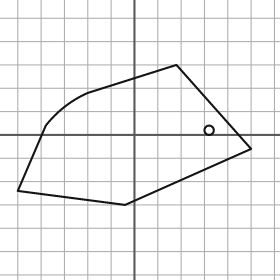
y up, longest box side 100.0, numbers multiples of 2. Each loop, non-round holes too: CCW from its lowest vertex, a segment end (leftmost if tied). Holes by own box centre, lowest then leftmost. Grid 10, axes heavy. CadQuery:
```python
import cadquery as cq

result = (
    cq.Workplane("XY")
    .moveTo(-4.0, -30.0)
    .lineTo(50.0, -6.0)
    .lineTo(18.0, 30.0)
    .lineTo(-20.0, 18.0)
    .threePointArc((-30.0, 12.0), (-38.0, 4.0))
    .lineTo(-50.0, -24.0)
    .close()
    .moveTo(32.0, 2.0)
    .circle(2.0)
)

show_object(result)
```